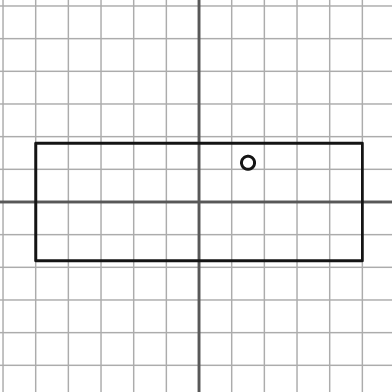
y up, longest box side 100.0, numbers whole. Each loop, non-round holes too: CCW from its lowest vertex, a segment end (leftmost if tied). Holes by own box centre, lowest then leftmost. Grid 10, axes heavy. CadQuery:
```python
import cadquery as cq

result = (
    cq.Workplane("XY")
    .moveTo(-50.0, -18.0)
    .lineTo(50.0, -18.0)
    .lineTo(50.0, 18.0)
    .lineTo(-50.0, 18.0)
    .close()
    .moveTo(15.0, 12.0)
    .circle(2.0)
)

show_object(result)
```